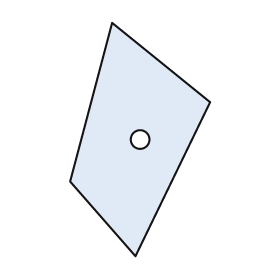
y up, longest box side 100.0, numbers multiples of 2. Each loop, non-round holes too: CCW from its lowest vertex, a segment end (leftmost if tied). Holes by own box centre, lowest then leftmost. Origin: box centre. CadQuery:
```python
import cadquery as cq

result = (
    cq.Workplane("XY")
    .moveTo(-2.0, -50.0)
    .lineTo(30.0, 16.0)
    .lineTo(-12.0, 50.0)
    .lineTo(-30.0, -18.0)
    .close()
    .moveTo(0.0, 0.0)
    .circle(4.0)
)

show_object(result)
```